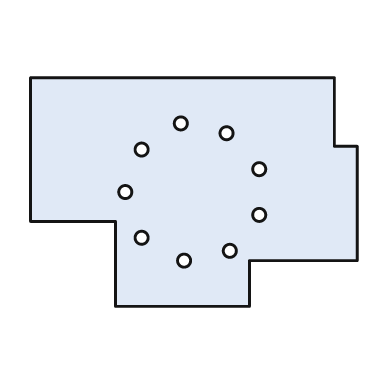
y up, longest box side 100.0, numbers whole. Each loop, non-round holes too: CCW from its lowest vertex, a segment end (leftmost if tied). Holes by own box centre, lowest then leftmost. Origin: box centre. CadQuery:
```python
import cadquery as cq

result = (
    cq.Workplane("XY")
    .moveTo(-24.0, -35.0)
    .lineTo(17.0, -35.0)
    .lineTo(17.0, -21.0)
    .lineTo(50.0, -21.0)
    .lineTo(50.0, 14.0)
    .lineTo(43.0, 14.0)
    .lineTo(43.0, 35.0)
    .lineTo(-50.0, 35.0)
    .lineTo(-50.0, -9.0)
    .lineTo(-24.0, -9.0)
    .close()
    .moveTo(-3.0, -21.0)
    .circle(2.0)
    .moveTo(11.0, -18.0)
    .circle(2.0)
    .moveTo(-16.0, -14.0)
    .circle(2.0)
    .moveTo(20.0, -7.0)
    .circle(2.0)
    .moveTo(-21.0, 0.0)
    .circle(2.0)
    .moveTo(20.0, 7.0)
    .circle(2.0)
    .moveTo(-16.0, 13.0)
    .circle(2.0)
    .moveTo(10.0, 18.0)
    .circle(2.0)
    .moveTo(-4.0, 21.0)
    .circle(2.0)
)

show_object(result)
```